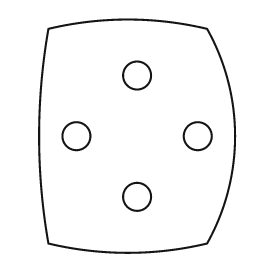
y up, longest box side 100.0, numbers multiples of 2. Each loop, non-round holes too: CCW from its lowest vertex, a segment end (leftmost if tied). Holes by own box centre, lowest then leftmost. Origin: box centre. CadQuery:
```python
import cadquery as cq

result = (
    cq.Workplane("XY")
    .moveTo(-38.0, -46.0)
    .threePointArc((-4.0, -50.0), (30.0, -46.0))
    .threePointArc((42.0, 0.0), (30.0, 46.0))
    .threePointArc((-4.0, 50.0), (-38.0, 46.0))
    .threePointArc((-42.0, 0.0), (-38.0, -46.0))
    .close()
    .moveTo(0.0, -26.0)
    .circle(6.0)
    .moveTo(-26.0, 0.0)
    .circle(6.0)
    .moveTo(26.0, 0.0)
    .circle(6.0)
    .moveTo(0.0, 26.0)
    .circle(6.0)
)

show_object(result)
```